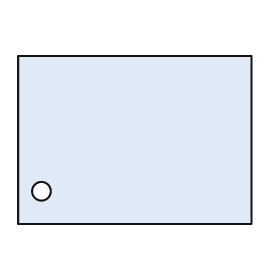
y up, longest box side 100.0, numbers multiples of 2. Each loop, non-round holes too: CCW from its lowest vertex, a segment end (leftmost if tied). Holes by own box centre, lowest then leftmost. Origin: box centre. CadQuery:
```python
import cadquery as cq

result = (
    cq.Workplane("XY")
    .moveTo(-50.0, -36.0)
    .lineTo(50.0, -36.0)
    .lineTo(50.0, 36.0)
    .lineTo(-50.0, 36.0)
    .close()
    .moveTo(-40.0, -22.0)
    .circle(4.0)
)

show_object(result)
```